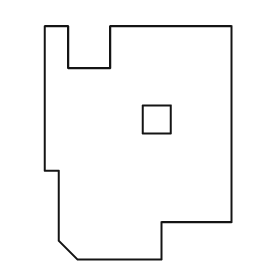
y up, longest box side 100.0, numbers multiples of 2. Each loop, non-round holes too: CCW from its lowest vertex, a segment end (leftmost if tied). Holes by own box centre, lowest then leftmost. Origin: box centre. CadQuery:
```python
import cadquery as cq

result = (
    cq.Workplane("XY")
    .moveTo(-26.0, -50.0)
    .lineTo(10.0, -50.0)
    .lineTo(10.0, -34.0)
    .lineTo(40.0, -34.0)
    .lineTo(40.0, 50.0)
    .lineTo(-12.0, 50.0)
    .lineTo(-12.0, 32.0)
    .lineTo(-30.0, 32.0)
    .lineTo(-30.0, 50.0)
    .lineTo(-40.0, 50.0)
    .lineTo(-40.0, -12.0)
    .lineTo(-34.0, -12.0)
    .lineTo(-34.0, -42.0)
    .close()
    .moveTo(2.0, 4.0)
    .lineTo(14.0, 4.0)
    .lineTo(14.0, 16.0)
    .lineTo(2.0, 16.0)
    .close()
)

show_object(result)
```